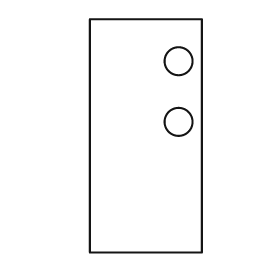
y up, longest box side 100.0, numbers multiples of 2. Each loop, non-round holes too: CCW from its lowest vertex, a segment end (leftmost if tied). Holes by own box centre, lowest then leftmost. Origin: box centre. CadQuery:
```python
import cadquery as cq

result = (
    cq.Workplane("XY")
    .moveTo(-24.0, -50.0)
    .lineTo(24.0, -50.0)
    .lineTo(24.0, 50.0)
    .lineTo(-24.0, 50.0)
    .close()
    .moveTo(14.0, 6.0)
    .circle(6.0)
    .moveTo(14.0, 32.0)
    .circle(6.0)
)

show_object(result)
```